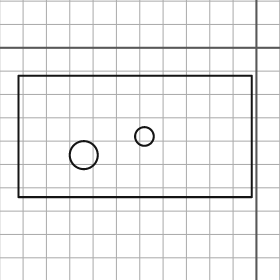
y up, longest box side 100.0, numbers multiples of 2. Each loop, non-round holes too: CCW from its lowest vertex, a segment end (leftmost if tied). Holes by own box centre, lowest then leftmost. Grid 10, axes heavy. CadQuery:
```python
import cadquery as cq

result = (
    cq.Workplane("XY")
    .moveTo(-102.0, -64.0)
    .lineTo(-2.0, -64.0)
    .lineTo(-2.0, -12.0)
    .lineTo(-102.0, -12.0)
    .close()
    .moveTo(-74.0, -46.0)
    .circle(6.0)
    .moveTo(-48.0, -38.0)
    .circle(4.0)
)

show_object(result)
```